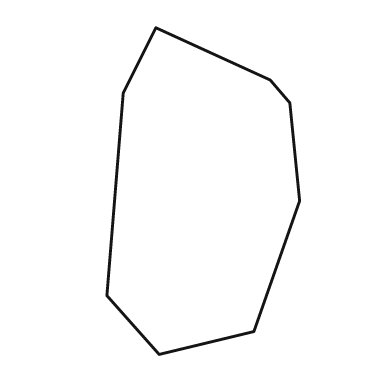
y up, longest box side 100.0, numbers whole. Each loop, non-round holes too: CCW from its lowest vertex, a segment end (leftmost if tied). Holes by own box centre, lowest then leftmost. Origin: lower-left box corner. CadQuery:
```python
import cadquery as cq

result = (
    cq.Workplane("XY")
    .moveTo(16.0, 0.0)
    .lineTo(45.0, 7.0)
    .lineTo(59.0, 47.0)
    .lineTo(56.0, 77.0)
    .lineTo(50.0, 84.0)
    .lineTo(15.0, 100.0)
    .lineTo(5.0, 80.0)
    .lineTo(0.0, 18.0)
    .close()
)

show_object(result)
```